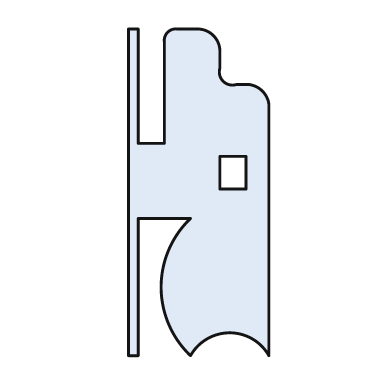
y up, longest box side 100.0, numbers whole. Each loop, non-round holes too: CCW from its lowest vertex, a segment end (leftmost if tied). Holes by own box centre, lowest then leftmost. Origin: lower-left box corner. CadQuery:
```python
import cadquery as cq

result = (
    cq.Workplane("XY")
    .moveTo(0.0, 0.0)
    .lineTo(3.0, 0.0)
    .lineTo(3.0, 42.0)
    .lineTo(19.0, 42.0)
    .threePointArc((10.0, 21.0), (19.0, 0.0))
    .threePointArc((31.0, 7.0), (43.0, 0.0))
    .lineTo(43.0, 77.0)
    .threePointArc((41.0, 81.0), (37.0, 83.0))
    .lineTo(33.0, 83.0)
    .threePointArc((29.0, 84.0), (28.0, 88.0))
    .lineTo(28.0, 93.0)
    .threePointArc((26.0, 98.0), (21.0, 100.0))
    .lineTo(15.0, 100.0)
    .threePointArc((12.0, 99.0), (11.0, 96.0))
    .lineTo(11.0, 65.0)
    .lineTo(3.0, 65.0)
    .lineTo(3.0, 100.0)
    .lineTo(0.0, 100.0)
    .close()
    .moveTo(28.0, 51.0)
    .lineTo(36.0, 51.0)
    .lineTo(36.0, 61.0)
    .lineTo(28.0, 61.0)
    .close()
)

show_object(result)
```